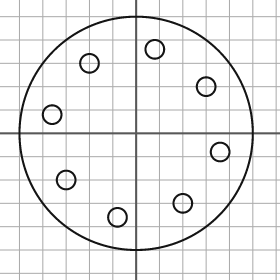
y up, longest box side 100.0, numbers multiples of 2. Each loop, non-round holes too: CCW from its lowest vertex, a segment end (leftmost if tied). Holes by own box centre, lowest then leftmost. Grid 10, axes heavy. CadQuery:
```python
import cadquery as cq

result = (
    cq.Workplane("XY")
    .moveTo(0.0, 0.0)
    .circle(50.0)
    .moveTo(-8.0, -36.0)
    .circle(4.0)
    .moveTo(20.0, -30.0)
    .circle(4.0)
    .moveTo(-30.0, -20.0)
    .circle(4.0)
    .moveTo(36.0, -8.0)
    .circle(4.0)
    .moveTo(-36.0, 8.0)
    .circle(4.0)
    .moveTo(30.0, 20.0)
    .circle(4.0)
    .moveTo(-20.0, 30.0)
    .circle(4.0)
    .moveTo(8.0, 36.0)
    .circle(4.0)
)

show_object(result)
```